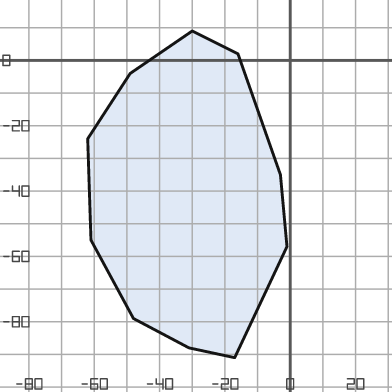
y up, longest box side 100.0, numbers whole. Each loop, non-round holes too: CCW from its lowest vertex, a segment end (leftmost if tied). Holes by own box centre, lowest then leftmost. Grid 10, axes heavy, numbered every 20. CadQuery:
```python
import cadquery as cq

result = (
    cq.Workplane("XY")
    .moveTo(-17.0, -91.0)
    .lineTo(-1.0, -57.0)
    .lineTo(-3.0, -35.0)
    .lineTo(-16.0, 2.0)
    .lineTo(-30.0, 9.0)
    .lineTo(-49.0, -4.0)
    .lineTo(-62.0, -24.0)
    .lineTo(-61.0, -55.0)
    .lineTo(-48.0, -79.0)
    .lineTo(-31.0, -88.0)
    .close()
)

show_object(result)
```